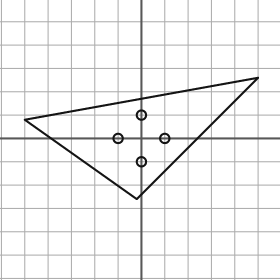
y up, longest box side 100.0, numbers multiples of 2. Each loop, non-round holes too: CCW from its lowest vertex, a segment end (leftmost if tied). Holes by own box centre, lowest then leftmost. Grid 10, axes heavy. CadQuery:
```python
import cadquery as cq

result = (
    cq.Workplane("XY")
    .moveTo(-2.0, -26.0)
    .lineTo(50.0, 26.0)
    .lineTo(-50.0, 8.0)
    .close()
    .moveTo(0.0, -10.0)
    .circle(2.0)
    .moveTo(-10.0, 0.0)
    .circle(2.0)
    .moveTo(10.0, 0.0)
    .circle(2.0)
    .moveTo(0.0, 10.0)
    .circle(2.0)
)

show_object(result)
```